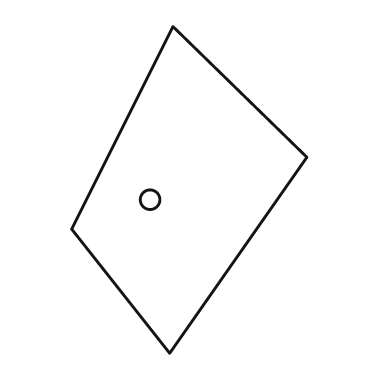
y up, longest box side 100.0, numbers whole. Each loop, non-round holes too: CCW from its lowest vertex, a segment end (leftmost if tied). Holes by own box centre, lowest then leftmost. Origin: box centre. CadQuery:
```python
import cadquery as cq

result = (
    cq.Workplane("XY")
    .moveTo(-6.0, -50.0)
    .lineTo(36.0, 10.0)
    .lineTo(-5.0, 50.0)
    .lineTo(-36.0, -12.0)
    .close()
    .moveTo(-12.0, -3.0)
    .circle(3.0)
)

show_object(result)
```